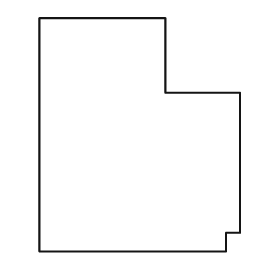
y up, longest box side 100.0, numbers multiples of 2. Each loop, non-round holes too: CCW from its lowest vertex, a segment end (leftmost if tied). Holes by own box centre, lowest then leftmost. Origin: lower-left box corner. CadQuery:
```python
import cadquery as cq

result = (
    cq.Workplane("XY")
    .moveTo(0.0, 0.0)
    .lineTo(80.0, 0.0)
    .lineTo(80.0, 8.0)
    .lineTo(86.0, 8.0)
    .lineTo(86.0, 68.0)
    .lineTo(54.0, 68.0)
    .lineTo(54.0, 100.0)
    .lineTo(0.0, 100.0)
    .close()
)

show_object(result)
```